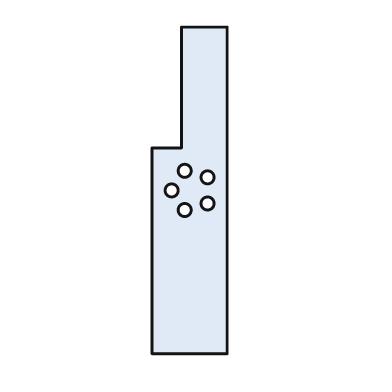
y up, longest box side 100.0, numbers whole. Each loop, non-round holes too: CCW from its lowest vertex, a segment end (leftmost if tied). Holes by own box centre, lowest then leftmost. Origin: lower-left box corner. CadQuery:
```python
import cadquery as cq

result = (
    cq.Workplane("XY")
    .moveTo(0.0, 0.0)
    .lineTo(23.0, 0.0)
    .lineTo(23.0, 100.0)
    .lineTo(9.0, 100.0)
    .lineTo(9.0, 63.0)
    .lineTo(0.0, 63.0)
    .close()
    .moveTo(10.0, 44.0)
    .circle(2.0)
    .moveTo(17.0, 46.0)
    .circle(2.0)
    .moveTo(6.0, 50.0)
    .circle(2.0)
    .moveTo(17.0, 54.0)
    .circle(2.0)
    .moveTo(10.0, 56.0)
    .circle(2.0)
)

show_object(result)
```